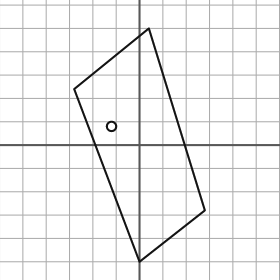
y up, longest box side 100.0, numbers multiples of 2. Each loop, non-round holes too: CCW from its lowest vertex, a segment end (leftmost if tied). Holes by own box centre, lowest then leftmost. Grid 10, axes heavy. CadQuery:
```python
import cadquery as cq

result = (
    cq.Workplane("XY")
    .moveTo(0.0, -50.0)
    .lineTo(28.0, -28.0)
    .lineTo(4.0, 50.0)
    .lineTo(-28.0, 24.0)
    .close()
    .moveTo(-12.0, 8.0)
    .circle(2.0)
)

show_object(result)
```